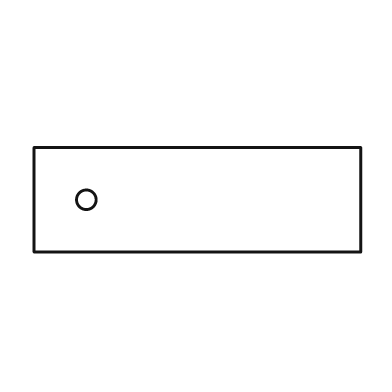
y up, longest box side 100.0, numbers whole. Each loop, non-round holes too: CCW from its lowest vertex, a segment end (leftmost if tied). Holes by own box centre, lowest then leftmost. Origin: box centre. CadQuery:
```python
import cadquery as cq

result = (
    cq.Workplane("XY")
    .moveTo(-50.0, -16.0)
    .lineTo(50.0, -16.0)
    .lineTo(50.0, 16.0)
    .lineTo(-50.0, 16.0)
    .close()
    .moveTo(-34.0, 0.0)
    .circle(3.0)
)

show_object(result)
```